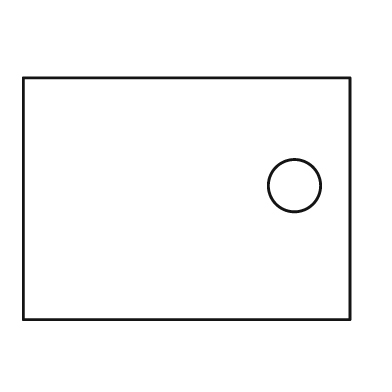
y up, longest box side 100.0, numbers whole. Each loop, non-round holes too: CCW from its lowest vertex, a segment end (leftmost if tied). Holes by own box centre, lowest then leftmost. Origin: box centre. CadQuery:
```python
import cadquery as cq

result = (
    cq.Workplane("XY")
    .moveTo(-50.0, -37.0)
    .lineTo(50.0, -37.0)
    .lineTo(50.0, 37.0)
    .lineTo(-50.0, 37.0)
    .close()
    .moveTo(33.0, 4.0)
    .circle(8.0)
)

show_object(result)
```